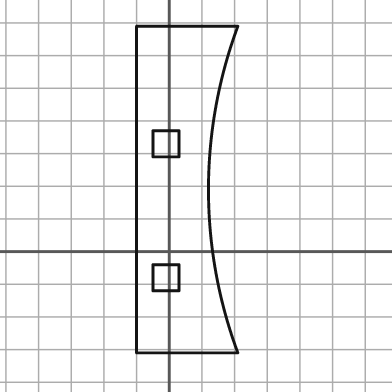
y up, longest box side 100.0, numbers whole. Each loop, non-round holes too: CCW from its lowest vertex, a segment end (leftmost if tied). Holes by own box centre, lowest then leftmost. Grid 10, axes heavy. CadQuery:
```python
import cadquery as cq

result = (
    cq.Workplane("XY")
    .moveTo(-10.0, -31.0)
    .lineTo(21.0, -31.0)
    .threePointArc((12.0, 19.0), (21.0, 69.0))
    .lineTo(-10.0, 69.0)
    .close()
    .moveTo(-5.0, -12.0)
    .lineTo(3.0, -12.0)
    .lineTo(3.0, -4.0)
    .lineTo(-5.0, -4.0)
    .close()
    .moveTo(-5.0, 29.0)
    .lineTo(3.0, 29.0)
    .lineTo(3.0, 37.0)
    .lineTo(-5.0, 37.0)
    .close()
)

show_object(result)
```